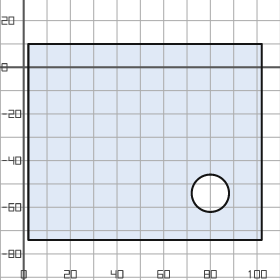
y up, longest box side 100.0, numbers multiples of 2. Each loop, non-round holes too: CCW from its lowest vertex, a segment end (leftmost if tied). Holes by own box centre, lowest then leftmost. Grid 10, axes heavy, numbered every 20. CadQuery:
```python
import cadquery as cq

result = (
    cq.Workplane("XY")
    .moveTo(2.0, -74.0)
    .lineTo(102.0, -74.0)
    .lineTo(102.0, 10.0)
    .lineTo(2.0, 10.0)
    .close()
    .moveTo(80.0, -54.0)
    .circle(8.0)
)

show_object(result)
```